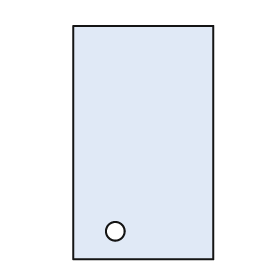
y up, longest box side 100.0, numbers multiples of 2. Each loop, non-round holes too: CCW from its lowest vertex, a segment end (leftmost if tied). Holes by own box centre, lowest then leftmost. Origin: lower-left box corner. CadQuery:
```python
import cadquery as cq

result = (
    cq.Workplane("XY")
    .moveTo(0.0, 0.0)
    .lineTo(60.0, 0.0)
    .lineTo(60.0, 100.0)
    .lineTo(0.0, 100.0)
    .close()
    .moveTo(18.0, 12.0)
    .circle(4.0)
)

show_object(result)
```